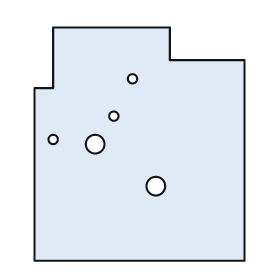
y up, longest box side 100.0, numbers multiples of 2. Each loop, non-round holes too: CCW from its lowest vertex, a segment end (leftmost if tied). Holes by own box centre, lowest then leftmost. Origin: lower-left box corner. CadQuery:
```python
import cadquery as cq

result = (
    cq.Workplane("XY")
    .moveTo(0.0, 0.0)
    .lineTo(90.0, 0.0)
    .lineTo(90.0, 86.0)
    .lineTo(58.0, 86.0)
    .lineTo(58.0, 100.0)
    .lineTo(8.0, 100.0)
    .lineTo(8.0, 74.0)
    .lineTo(0.0, 74.0)
    .close()
    .moveTo(52.0, 32.0)
    .circle(4.0)
    .moveTo(26.0, 50.0)
    .circle(4.0)
    .moveTo(8.0, 52.0)
    .circle(2.0)
    .moveTo(34.0, 62.0)
    .circle(2.0)
    .moveTo(42.0, 78.0)
    .circle(2.0)
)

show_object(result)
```